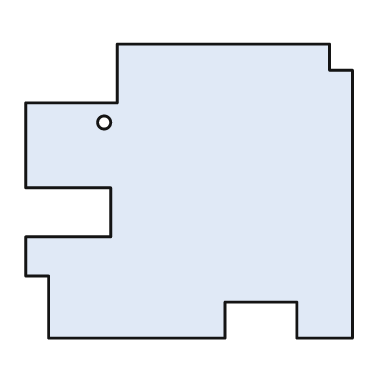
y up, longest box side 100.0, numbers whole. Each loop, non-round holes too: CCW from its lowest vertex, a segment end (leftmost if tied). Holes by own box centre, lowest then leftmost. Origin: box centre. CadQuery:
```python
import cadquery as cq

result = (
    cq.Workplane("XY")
    .moveTo(-43.0, -45.0)
    .lineTo(11.0, -45.0)
    .lineTo(11.0, -34.0)
    .lineTo(33.0, -34.0)
    .lineTo(33.0, -45.0)
    .lineTo(50.0, -45.0)
    .lineTo(50.0, 37.0)
    .lineTo(43.0, 37.0)
    .lineTo(43.0, 45.0)
    .lineTo(-22.0, 45.0)
    .lineTo(-22.0, 27.0)
    .lineTo(-50.0, 27.0)
    .lineTo(-50.0, 1.0)
    .lineTo(-24.0, 1.0)
    .lineTo(-24.0, -14.0)
    .lineTo(-50.0, -14.0)
    .lineTo(-50.0, -26.0)
    .lineTo(-43.0, -26.0)
    .close()
    .moveTo(-26.0, 21.0)
    .circle(2.0)
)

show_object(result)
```